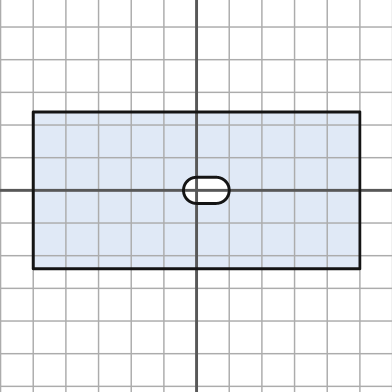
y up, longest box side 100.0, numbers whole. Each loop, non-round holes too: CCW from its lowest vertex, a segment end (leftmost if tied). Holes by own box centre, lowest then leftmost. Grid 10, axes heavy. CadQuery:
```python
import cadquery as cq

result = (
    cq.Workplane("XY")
    .moveTo(-50.0, -24.0)
    .lineTo(50.0, -24.0)
    .lineTo(50.0, 24.0)
    .lineTo(-50.0, 24.0)
    .close()
    .moveTo(0.0, -4.0)
    .lineTo(6.0, -4.0)
    .threePointArc((10.0, 0.0), (6.0, 4.0))
    .lineTo(0.0, 4.0)
    .threePointArc((-4.0, 0.0), (0.0, -4.0))
    .close()
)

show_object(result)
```